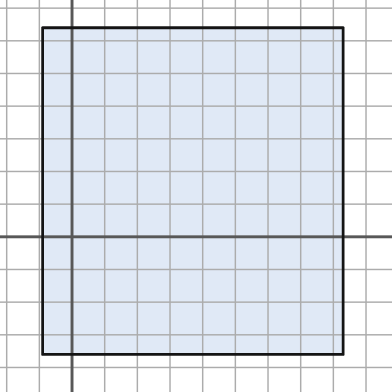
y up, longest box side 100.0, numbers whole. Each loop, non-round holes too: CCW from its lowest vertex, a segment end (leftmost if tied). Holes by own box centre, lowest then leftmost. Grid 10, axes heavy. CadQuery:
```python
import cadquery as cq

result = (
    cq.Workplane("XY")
    .moveTo(-9.0, -36.0)
    .lineTo(83.0, -36.0)
    .lineTo(83.0, 64.0)
    .lineTo(-9.0, 64.0)
    .close()
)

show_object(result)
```